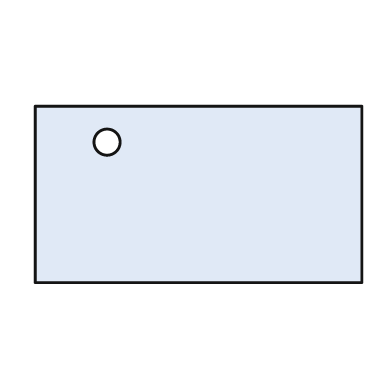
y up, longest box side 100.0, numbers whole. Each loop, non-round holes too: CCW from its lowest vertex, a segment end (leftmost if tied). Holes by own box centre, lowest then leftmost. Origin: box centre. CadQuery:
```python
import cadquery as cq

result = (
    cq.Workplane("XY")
    .moveTo(-50.0, -27.0)
    .lineTo(50.0, -27.0)
    .lineTo(50.0, 27.0)
    .lineTo(-50.0, 27.0)
    .close()
    .moveTo(-28.0, 16.0)
    .circle(4.0)
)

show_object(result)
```